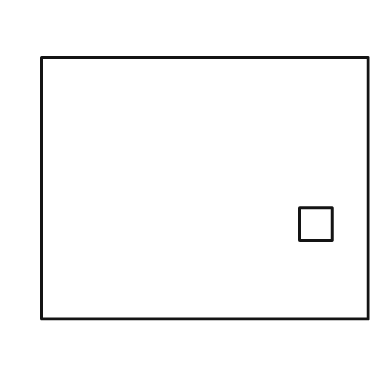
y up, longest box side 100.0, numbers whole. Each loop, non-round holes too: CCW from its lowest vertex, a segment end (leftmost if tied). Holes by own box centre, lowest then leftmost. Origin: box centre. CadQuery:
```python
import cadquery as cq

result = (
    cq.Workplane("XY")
    .moveTo(-50.0, -40.0)
    .lineTo(50.0, -40.0)
    .lineTo(50.0, 40.0)
    .lineTo(-50.0, 40.0)
    .close()
    .moveTo(29.0, -16.0)
    .lineTo(39.0, -16.0)
    .lineTo(39.0, -6.0)
    .lineTo(29.0, -6.0)
    .close()
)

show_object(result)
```